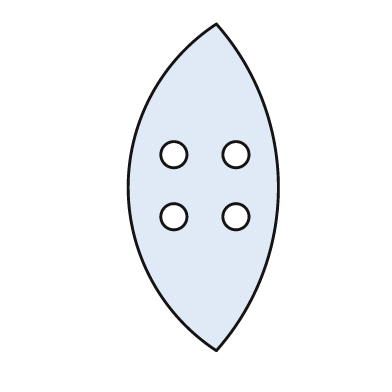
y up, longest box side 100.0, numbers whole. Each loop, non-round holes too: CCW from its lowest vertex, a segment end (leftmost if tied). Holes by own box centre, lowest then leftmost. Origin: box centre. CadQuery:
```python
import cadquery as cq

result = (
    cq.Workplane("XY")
    .moveTo(4.0, -50.0)
    .threePointArc((23.0, 0.0), (4.0, 50.0))
    .threePointArc((-23.0, 0.0), (4.0, -50.0))
    .close()
    .moveTo(-9.0, -9.0)
    .circle(4.0)
    .moveTo(10.0, -9.0)
    .circle(4.0)
    .moveTo(-9.0, 10.0)
    .circle(4.0)
    .moveTo(10.0, 10.0)
    .circle(4.0)
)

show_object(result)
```